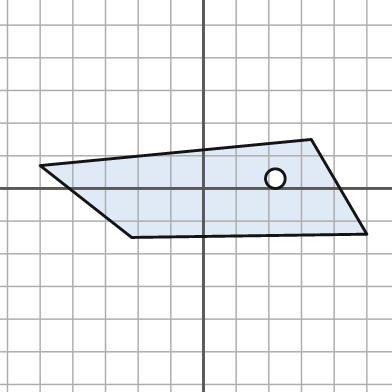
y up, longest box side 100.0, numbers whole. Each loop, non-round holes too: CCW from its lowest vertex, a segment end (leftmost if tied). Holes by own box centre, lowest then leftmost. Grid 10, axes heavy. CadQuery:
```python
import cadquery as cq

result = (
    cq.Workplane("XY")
    .moveTo(-22.0, -15.0)
    .lineTo(50.0, -14.0)
    .lineTo(33.0, 15.0)
    .lineTo(-50.0, 7.0)
    .close()
    .moveTo(22.0, 3.0)
    .circle(3.0)
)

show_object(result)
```